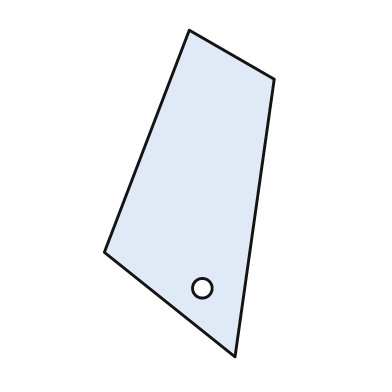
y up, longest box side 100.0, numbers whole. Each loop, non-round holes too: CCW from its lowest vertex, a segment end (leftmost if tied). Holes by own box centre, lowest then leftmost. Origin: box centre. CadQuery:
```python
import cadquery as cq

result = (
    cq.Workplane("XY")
    .moveTo(14.0, -50.0)
    .lineTo(26.0, 35.0)
    .lineTo(0.0, 50.0)
    .lineTo(-26.0, -18.0)
    .close()
    .moveTo(4.0, -29.0)
    .circle(3.0)
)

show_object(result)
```